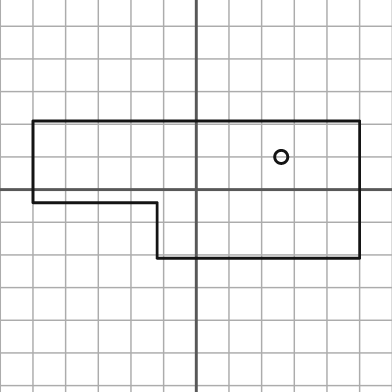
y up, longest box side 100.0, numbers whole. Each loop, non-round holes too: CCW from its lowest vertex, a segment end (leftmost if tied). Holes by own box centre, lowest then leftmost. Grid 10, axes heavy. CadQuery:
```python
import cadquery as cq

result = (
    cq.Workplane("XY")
    .moveTo(-12.0, -21.0)
    .lineTo(50.0, -21.0)
    .lineTo(50.0, 21.0)
    .lineTo(-50.0, 21.0)
    .lineTo(-50.0, -4.0)
    .lineTo(-12.0, -4.0)
    .close()
    .moveTo(26.0, 10.0)
    .circle(2.0)
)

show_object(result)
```